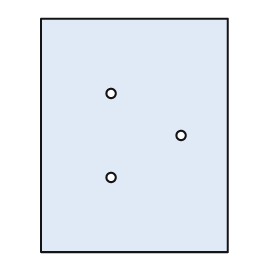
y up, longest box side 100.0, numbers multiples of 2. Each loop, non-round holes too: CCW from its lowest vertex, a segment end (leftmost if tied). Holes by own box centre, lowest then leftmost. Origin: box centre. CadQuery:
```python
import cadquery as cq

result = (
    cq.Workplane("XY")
    .moveTo(-40.0, -50.0)
    .lineTo(40.0, -50.0)
    .lineTo(40.0, 50.0)
    .lineTo(-40.0, 50.0)
    .close()
    .moveTo(-10.0, -18.0)
    .circle(2.0)
    .moveTo(20.0, 0.0)
    .circle(2.0)
    .moveTo(-10.0, 18.0)
    .circle(2.0)
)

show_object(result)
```